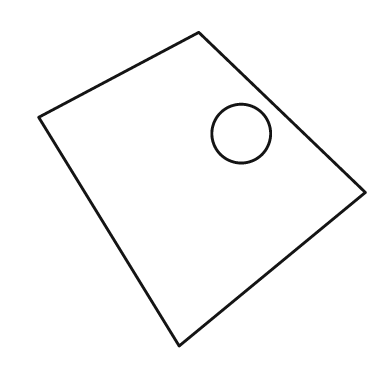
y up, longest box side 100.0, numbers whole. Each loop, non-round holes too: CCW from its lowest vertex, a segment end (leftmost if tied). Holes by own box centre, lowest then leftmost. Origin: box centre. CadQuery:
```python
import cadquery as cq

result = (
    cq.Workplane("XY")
    .moveTo(-7.0, -48.0)
    .lineTo(50.0, -1.0)
    .lineTo(-1.0, 48.0)
    .lineTo(-50.0, 22.0)
    .close()
    .moveTo(12.0, 17.0)
    .circle(9.0)
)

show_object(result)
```